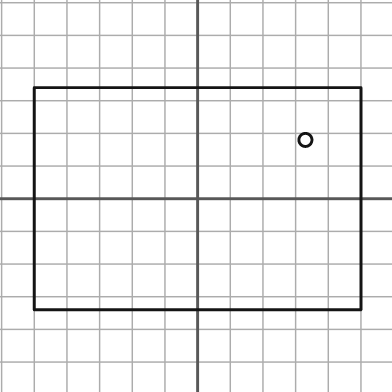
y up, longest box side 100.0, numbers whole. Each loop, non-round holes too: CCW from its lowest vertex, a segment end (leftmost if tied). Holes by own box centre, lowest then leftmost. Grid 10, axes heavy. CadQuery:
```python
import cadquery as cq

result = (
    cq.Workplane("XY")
    .moveTo(-50.0, -34.0)
    .lineTo(50.0, -34.0)
    .lineTo(50.0, 34.0)
    .lineTo(-50.0, 34.0)
    .close()
    .moveTo(33.0, 18.0)
    .circle(2.0)
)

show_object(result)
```